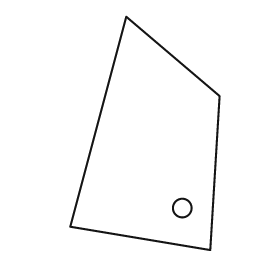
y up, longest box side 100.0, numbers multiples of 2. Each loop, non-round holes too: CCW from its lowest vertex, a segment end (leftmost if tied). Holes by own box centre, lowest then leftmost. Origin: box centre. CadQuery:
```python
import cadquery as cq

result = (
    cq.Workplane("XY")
    .moveTo(28.0, -50.0)
    .lineTo(32.0, 16.0)
    .lineTo(-8.0, 50.0)
    .lineTo(-32.0, -40.0)
    .close()
    .moveTo(16.0, -32.0)
    .circle(4.0)
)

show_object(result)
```